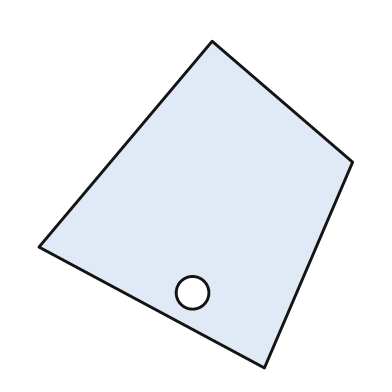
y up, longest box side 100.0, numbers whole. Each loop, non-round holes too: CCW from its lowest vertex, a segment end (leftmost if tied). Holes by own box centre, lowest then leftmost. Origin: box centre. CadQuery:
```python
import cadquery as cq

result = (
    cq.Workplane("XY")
    .moveTo(21.0, -50.0)
    .lineTo(48.0, 13.0)
    .lineTo(5.0, 50.0)
    .lineTo(-48.0, -13.0)
    .close()
    .moveTo(-1.0, -27.0)
    .circle(5.0)
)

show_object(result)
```